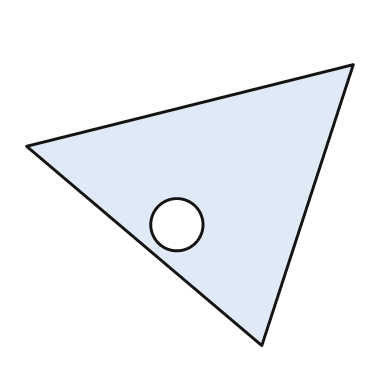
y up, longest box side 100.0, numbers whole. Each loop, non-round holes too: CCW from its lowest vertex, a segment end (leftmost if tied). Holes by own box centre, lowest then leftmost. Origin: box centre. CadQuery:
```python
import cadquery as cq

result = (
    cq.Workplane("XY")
    .moveTo(22.0, -43.0)
    .lineTo(50.0, 43.0)
    .lineTo(-50.0, 18.0)
    .close()
    .moveTo(-4.0, -6.0)
    .circle(8.0)
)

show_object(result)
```